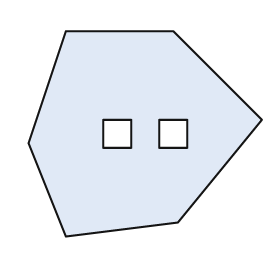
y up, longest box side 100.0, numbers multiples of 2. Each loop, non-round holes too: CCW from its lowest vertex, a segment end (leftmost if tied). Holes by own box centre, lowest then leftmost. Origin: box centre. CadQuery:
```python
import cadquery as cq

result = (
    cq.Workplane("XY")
    .moveTo(-34.0, -44.0)
    .lineTo(14.0, -38.0)
    .lineTo(50.0, 6.0)
    .lineTo(12.0, 44.0)
    .lineTo(-34.0, 44.0)
    .lineTo(-50.0, -4.0)
    .close()
    .moveTo(-18.0, -6.0)
    .lineTo(-6.0, -6.0)
    .lineTo(-6.0, 6.0)
    .lineTo(-18.0, 6.0)
    .close()
    .moveTo(6.0, -6.0)
    .lineTo(18.0, -6.0)
    .lineTo(18.0, 6.0)
    .lineTo(6.0, 6.0)
    .close()
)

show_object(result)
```